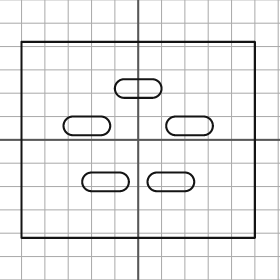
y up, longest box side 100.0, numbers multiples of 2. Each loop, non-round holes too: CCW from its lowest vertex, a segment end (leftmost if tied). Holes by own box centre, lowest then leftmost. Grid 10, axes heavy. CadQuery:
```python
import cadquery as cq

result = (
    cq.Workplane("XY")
    .moveTo(-50.0, -42.0)
    .lineTo(50.0, -42.0)
    .lineTo(50.0, 42.0)
    .lineTo(-50.0, 42.0)
    .close()
    .moveTo(-20.0, -22.0)
    .lineTo(-8.0, -22.0)
    .threePointArc((-4.0, -18.0), (-8.0, -14.0))
    .lineTo(-20.0, -14.0)
    .threePointArc((-24.0, -18.0), (-20.0, -22.0))
    .close()
    .moveTo(8.0, -22.0)
    .lineTo(20.0, -22.0)
    .threePointArc((24.0, -18.0), (20.0, -14.0))
    .lineTo(8.0, -14.0)
    .threePointArc((4.0, -18.0), (8.0, -22.0))
    .close()
    .moveTo(-28.0, 2.0)
    .lineTo(-16.0, 2.0)
    .threePointArc((-12.0, 6.0), (-16.0, 10.0))
    .lineTo(-28.0, 10.0)
    .threePointArc((-32.0, 6.0), (-28.0, 2.0))
    .close()
    .moveTo(16.0, 2.0)
    .lineTo(28.0, 2.0)
    .threePointArc((32.0, 6.0), (28.0, 10.0))
    .lineTo(16.0, 10.0)
    .threePointArc((12.0, 6.0), (16.0, 2.0))
    .close()
    .moveTo(-6.0, 18.0)
    .lineTo(6.0, 18.0)
    .threePointArc((10.0, 22.0), (6.0, 26.0))
    .lineTo(-6.0, 26.0)
    .threePointArc((-10.0, 22.0), (-6.0, 18.0))
    .close()
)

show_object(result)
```